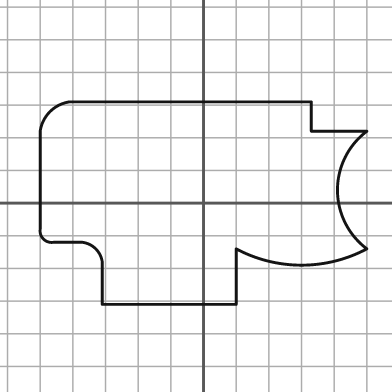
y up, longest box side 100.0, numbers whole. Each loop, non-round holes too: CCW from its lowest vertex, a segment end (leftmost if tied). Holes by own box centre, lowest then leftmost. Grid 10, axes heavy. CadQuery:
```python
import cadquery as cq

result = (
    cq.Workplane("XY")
    .moveTo(-31.0, -31.0)
    .lineTo(10.0, -31.0)
    .lineTo(10.0, -14.0)
    .threePointArc((30.0, -19.0), (50.0, -14.0))
    .threePointArc((41.0, 4.0), (50.0, 22.0))
    .lineTo(33.0, 22.0)
    .lineTo(33.0, 31.0)
    .lineTo(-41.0, 31.0)
    .threePointArc((-47.0, 28.0), (-50.0, 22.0))
    .lineTo(-50.0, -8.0)
    .threePointArc((-49.0, -11.0), (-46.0, -12.0))
    .lineTo(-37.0, -12.0)
    .threePointArc((-33.0, -14.0), (-31.0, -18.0))
    .close()
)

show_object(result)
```